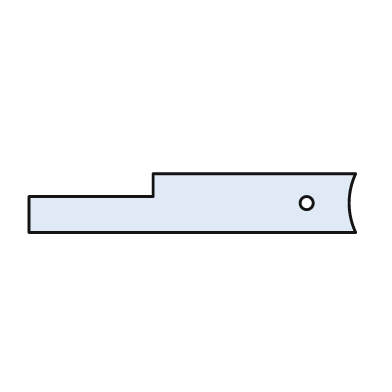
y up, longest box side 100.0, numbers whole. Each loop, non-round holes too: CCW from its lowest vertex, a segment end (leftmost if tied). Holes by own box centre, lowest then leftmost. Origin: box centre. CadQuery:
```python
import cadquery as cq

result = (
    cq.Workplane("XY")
    .moveTo(-50.0, -9.0)
    .lineTo(50.0, -9.0)
    .threePointArc((48.0, 0.0), (50.0, 9.0))
    .lineTo(-12.0, 9.0)
    .lineTo(-12.0, 2.0)
    .lineTo(-50.0, 2.0)
    .close()
    .moveTo(35.0, 0.0)
    .circle(2.0)
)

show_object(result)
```